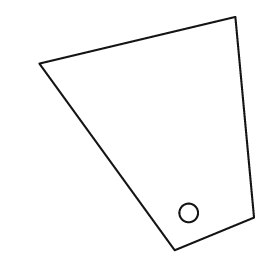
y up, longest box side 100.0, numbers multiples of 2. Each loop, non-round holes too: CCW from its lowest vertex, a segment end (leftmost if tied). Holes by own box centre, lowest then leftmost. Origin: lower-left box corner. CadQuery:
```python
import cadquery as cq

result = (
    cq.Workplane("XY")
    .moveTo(58.0, 0.0)
    .lineTo(92.0, 14.0)
    .lineTo(84.0, 100.0)
    .lineTo(0.0, 80.0)
    .close()
    .moveTo(64.0, 16.0)
    .circle(4.0)
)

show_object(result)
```